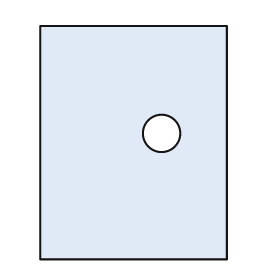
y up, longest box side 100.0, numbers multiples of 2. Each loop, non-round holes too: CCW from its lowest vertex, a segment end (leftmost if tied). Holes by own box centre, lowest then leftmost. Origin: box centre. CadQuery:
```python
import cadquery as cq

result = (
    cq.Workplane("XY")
    .moveTo(-40.0, -50.0)
    .lineTo(40.0, -50.0)
    .lineTo(40.0, 50.0)
    .lineTo(-40.0, 50.0)
    .close()
    .moveTo(12.0, 4.0)
    .circle(8.0)
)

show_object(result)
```